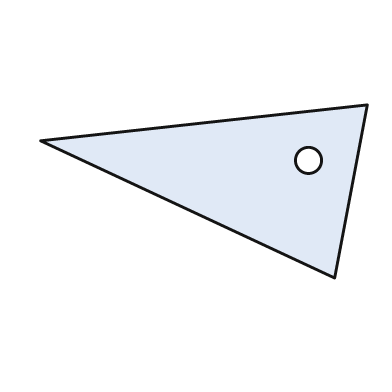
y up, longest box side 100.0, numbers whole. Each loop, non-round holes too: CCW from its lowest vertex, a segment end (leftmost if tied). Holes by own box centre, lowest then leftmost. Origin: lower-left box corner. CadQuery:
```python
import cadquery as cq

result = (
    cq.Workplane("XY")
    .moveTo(90.0, 0.0)
    .lineTo(100.0, 53.0)
    .lineTo(0.0, 42.0)
    .close()
    .moveTo(82.0, 36.0)
    .circle(4.0)
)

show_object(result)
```